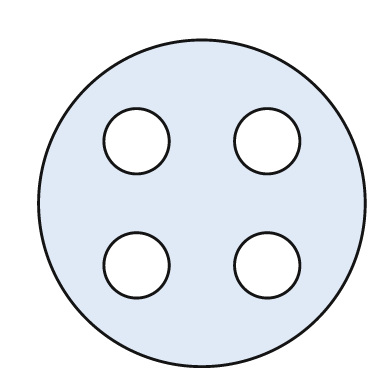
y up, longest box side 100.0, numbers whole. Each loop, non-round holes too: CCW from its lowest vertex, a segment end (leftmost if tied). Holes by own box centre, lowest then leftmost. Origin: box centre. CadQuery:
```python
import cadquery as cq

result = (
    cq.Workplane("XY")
    .moveTo(0.0, 0.0)
    .circle(50.0)
    .moveTo(-20.0, -19.0)
    .circle(10.0)
    .moveTo(20.0, -19.0)
    .circle(10.0)
    .moveTo(-20.0, 19.0)
    .circle(10.0)
    .moveTo(20.0, 19.0)
    .circle(10.0)
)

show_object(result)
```